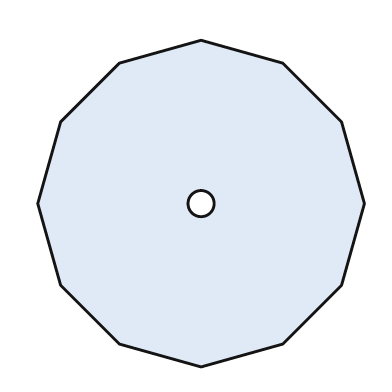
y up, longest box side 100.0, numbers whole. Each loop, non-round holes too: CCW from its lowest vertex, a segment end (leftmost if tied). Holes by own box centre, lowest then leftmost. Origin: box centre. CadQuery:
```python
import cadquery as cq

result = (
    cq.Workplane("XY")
    .moveTo(0.0, -50.0)
    .lineTo(25.0, -43.0)
    .lineTo(43.0, -25.0)
    .lineTo(50.0, 0.0)
    .lineTo(43.0, 25.0)
    .lineTo(25.0, 43.0)
    .lineTo(0.0, 50.0)
    .lineTo(-25.0, 43.0)
    .lineTo(-43.0, 25.0)
    .lineTo(-50.0, 0.0)
    .lineTo(-43.0, -25.0)
    .lineTo(-25.0, -43.0)
    .close()
    .moveTo(0.0, 0.0)
    .circle(4.0)
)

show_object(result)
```